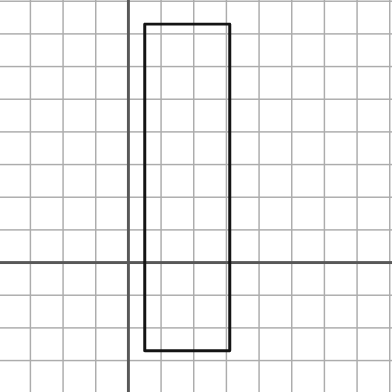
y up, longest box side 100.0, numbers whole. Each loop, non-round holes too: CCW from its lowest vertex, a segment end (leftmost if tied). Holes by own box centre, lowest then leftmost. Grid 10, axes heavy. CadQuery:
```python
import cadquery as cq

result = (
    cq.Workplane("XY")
    .moveTo(5.0, -27.0)
    .lineTo(31.0, -27.0)
    .lineTo(31.0, 73.0)
    .lineTo(5.0, 73.0)
    .close()
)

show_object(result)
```